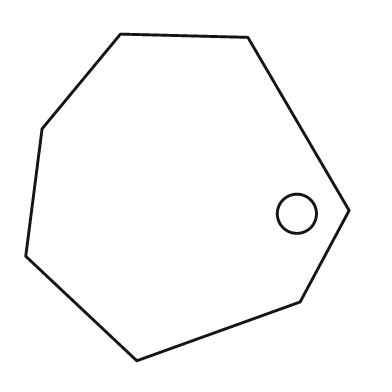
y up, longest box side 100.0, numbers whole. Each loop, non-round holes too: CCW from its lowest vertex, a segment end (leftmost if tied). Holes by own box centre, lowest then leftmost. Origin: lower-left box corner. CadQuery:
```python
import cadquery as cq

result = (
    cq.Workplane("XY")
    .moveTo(34.0, 0.0)
    .lineTo(84.0, 18.0)
    .lineTo(99.0, 46.0)
    .lineTo(68.0, 99.0)
    .lineTo(29.0, 100.0)
    .lineTo(5.0, 71.0)
    .lineTo(0.0, 32.0)
    .close()
    .moveTo(83.0, 45.0)
    .circle(6.0)
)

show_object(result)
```